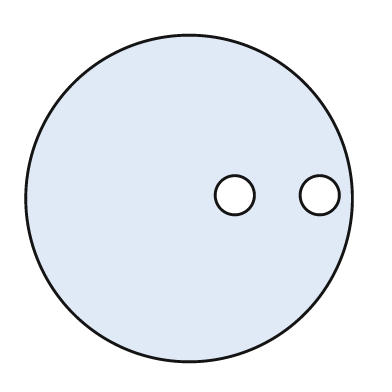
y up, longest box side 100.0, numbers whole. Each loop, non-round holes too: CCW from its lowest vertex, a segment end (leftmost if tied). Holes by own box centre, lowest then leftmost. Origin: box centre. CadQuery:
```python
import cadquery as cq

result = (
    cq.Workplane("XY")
    .moveTo(0.0, 0.0)
    .circle(50.0)
    .moveTo(14.0, 1.0)
    .circle(6.0)
    .moveTo(40.0, 1.0)
    .circle(6.0)
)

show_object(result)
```